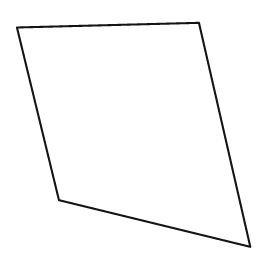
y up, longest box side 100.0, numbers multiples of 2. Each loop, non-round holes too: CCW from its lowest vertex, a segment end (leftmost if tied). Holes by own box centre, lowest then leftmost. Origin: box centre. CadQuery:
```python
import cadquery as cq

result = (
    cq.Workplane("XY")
    .moveTo(50.0, -48.0)
    .lineTo(28.0, 48.0)
    .lineTo(-50.0, 46.0)
    .lineTo(-32.0, -28.0)
    .close()
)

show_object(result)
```